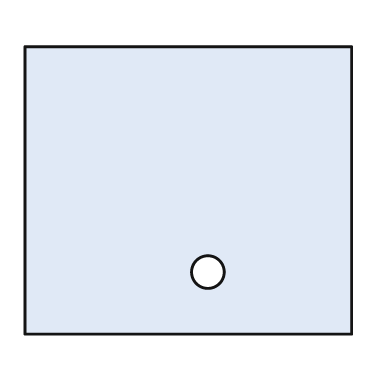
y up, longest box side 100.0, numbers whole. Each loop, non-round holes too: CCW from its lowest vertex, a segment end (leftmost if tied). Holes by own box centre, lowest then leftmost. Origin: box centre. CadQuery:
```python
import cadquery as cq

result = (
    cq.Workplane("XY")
    .moveTo(-50.0, -44.0)
    .lineTo(50.0, -44.0)
    .lineTo(50.0, 44.0)
    .lineTo(-50.0, 44.0)
    .close()
    .moveTo(6.0, -25.0)
    .circle(5.0)
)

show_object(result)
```